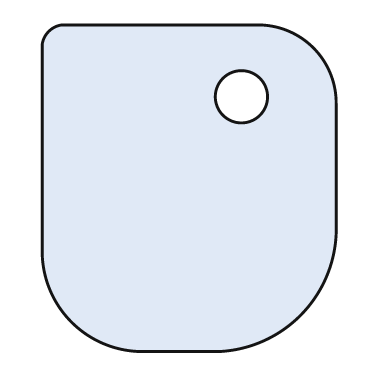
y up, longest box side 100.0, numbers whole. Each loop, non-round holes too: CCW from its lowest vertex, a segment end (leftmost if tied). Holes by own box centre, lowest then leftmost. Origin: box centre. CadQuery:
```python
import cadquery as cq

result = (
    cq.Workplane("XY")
    .moveTo(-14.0, -50.0)
    .lineTo(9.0, -50.0)
    .threePointArc((34.0, -39.0), (45.0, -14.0))
    .lineTo(45.0, 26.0)
    .threePointArc((38.0, 43.0), (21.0, 50.0))
    .lineTo(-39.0, 50.0)
    .threePointArc((-43.0, 48.0), (-45.0, 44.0))
    .lineTo(-45.0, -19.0)
    .threePointArc((-36.0, -41.0), (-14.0, -50.0))
    .close()
    .moveTo(16.0, 28.0)
    .circle(8.0)
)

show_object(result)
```